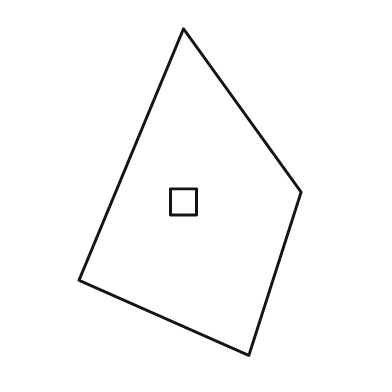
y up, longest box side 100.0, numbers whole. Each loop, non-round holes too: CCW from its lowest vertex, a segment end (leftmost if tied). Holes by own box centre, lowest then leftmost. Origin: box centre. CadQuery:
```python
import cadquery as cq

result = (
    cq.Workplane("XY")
    .moveTo(18.0, -50.0)
    .lineTo(34.0, 0.0)
    .lineTo(-2.0, 50.0)
    .lineTo(-34.0, -27.0)
    .close()
    .moveTo(-6.0, -7.0)
    .lineTo(2.0, -7.0)
    .lineTo(2.0, 1.0)
    .lineTo(-6.0, 1.0)
    .close()
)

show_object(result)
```